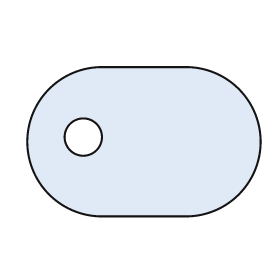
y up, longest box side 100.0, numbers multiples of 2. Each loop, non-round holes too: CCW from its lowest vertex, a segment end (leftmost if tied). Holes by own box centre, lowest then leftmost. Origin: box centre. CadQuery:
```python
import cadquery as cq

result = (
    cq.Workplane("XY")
    .moveTo(-18.0, -32.0)
    .lineTo(18.0, -32.0)
    .threePointArc((50.0, 0.0), (18.0, 32.0))
    .lineTo(-18.0, 32.0)
    .threePointArc((-50.0, 0.0), (-18.0, -32.0))
    .close()
    .moveTo(-26.0, 2.0)
    .circle(8.0)
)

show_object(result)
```